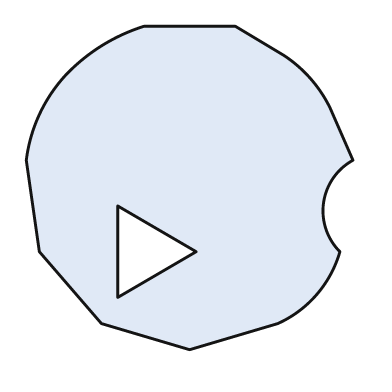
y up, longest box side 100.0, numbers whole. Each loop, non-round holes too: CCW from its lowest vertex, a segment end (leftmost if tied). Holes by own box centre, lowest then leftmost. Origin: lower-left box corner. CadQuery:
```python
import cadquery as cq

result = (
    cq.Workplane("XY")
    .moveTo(50.0, 0.0)
    .lineTo(77.0, 8.0)
    .threePointArc((89.0, 17.0), (96.0, 30.0))
    .threePointArc((91.0, 45.0), (100.0, 58.0))
    .lineTo(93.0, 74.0)
    .threePointArc((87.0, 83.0), (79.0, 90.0))
    .lineTo(64.0, 99.0)
    .lineTo(36.0, 99.0)
    .threePointArc((23.0, 93.0), (12.0, 84.0))
    .threePointArc((4.0, 72.0), (0.0, 58.0))
    .lineTo(4.0, 30.0)
    .lineTo(23.0, 8.0)
    .close()
    .moveTo(28.0, 16.0)
    .lineTo(52.0, 30.0)
    .lineTo(28.0, 44.0)
    .close()
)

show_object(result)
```